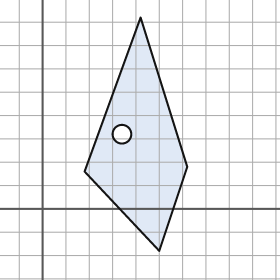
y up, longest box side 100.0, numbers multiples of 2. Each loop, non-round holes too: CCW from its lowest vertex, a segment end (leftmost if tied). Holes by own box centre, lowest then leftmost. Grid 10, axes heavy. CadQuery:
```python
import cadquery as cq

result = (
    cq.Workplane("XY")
    .moveTo(50.0, -18.0)
    .lineTo(62.0, 18.0)
    .lineTo(42.0, 82.0)
    .lineTo(18.0, 16.0)
    .close()
    .moveTo(34.0, 32.0)
    .circle(4.0)
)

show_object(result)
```